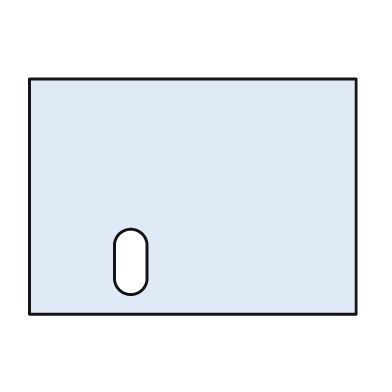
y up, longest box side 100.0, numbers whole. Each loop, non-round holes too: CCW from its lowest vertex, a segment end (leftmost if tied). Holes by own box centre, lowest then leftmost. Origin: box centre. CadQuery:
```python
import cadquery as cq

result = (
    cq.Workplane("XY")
    .moveTo(-50.0, -36.0)
    .lineTo(50.0, -36.0)
    .lineTo(50.0, 36.0)
    .lineTo(-50.0, 36.0)
    .close()
    .moveTo(-24.0, -25.0)
    .threePointArc((-19.0, -30.0), (-14.0, -25.0))
    .lineTo(-14.0, -15.0)
    .threePointArc((-19.0, -10.0), (-24.0, -15.0))
    .close()
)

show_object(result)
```